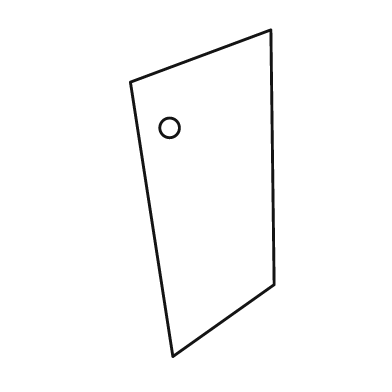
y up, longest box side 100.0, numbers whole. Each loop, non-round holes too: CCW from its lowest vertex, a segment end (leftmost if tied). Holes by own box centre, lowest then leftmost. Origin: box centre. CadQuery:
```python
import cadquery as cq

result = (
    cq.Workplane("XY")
    .moveTo(-9.0, -50.0)
    .lineTo(22.0, -28.0)
    .lineTo(21.0, 50.0)
    .lineTo(-22.0, 34.0)
    .close()
    .moveTo(-10.0, 20.0)
    .circle(3.0)
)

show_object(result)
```